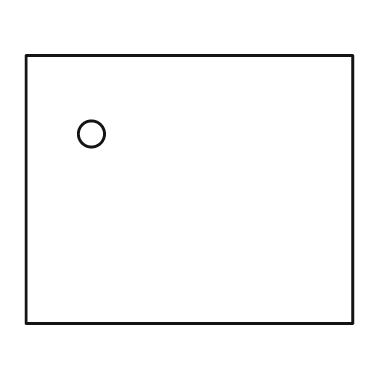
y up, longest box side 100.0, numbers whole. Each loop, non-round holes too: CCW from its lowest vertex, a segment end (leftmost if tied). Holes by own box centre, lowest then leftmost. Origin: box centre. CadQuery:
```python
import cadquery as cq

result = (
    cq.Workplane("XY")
    .moveTo(-50.0, -41.0)
    .lineTo(50.0, -41.0)
    .lineTo(50.0, 41.0)
    .lineTo(-50.0, 41.0)
    .close()
    .moveTo(-30.0, 17.0)
    .circle(4.0)
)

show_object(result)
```